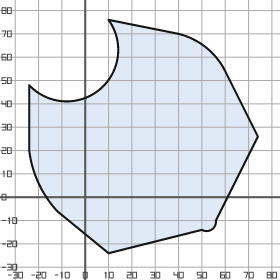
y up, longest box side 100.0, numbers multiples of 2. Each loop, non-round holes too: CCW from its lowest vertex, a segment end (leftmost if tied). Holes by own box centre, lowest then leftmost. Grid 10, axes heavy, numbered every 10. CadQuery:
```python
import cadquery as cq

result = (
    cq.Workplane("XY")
    .moveTo(10.0, -24.0)
    .lineTo(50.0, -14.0)
    .threePointArc((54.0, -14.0), (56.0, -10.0))
    .lineTo(74.0, 26.0)
    .lineTo(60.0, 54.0)
    .threePointArc((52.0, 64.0), (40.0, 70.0))
    .lineTo(10.0, 76.0)
    .threePointArc((6.0, 46.0), (-24.0, 48.0))
    .lineTo(-24.0, 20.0)
    .threePointArc((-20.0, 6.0), (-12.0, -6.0))
    .close()
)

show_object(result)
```